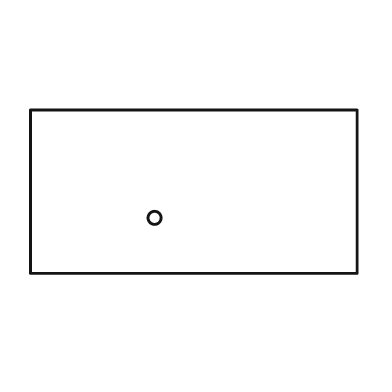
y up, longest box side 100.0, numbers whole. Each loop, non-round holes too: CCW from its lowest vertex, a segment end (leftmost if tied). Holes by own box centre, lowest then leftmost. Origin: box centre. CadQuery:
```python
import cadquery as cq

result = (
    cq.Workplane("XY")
    .moveTo(-50.0, -25.0)
    .lineTo(50.0, -25.0)
    .lineTo(50.0, 25.0)
    .lineTo(-50.0, 25.0)
    .close()
    .moveTo(-12.0, -8.0)
    .circle(2.0)
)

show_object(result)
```